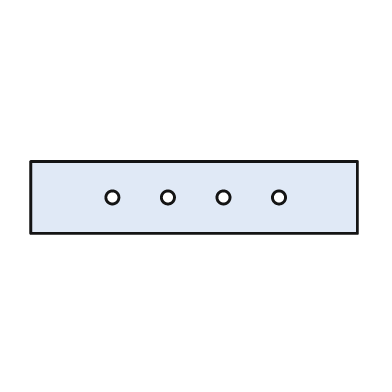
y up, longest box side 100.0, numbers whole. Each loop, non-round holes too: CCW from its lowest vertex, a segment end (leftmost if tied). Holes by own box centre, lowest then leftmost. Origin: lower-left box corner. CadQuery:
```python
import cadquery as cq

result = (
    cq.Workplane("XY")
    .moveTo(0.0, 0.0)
    .lineTo(100.0, 0.0)
    .lineTo(100.0, 22.0)
    .lineTo(0.0, 22.0)
    .close()
    .moveTo(25.0, 11.0)
    .circle(2.0)
    .moveTo(42.0, 11.0)
    .circle(2.0)
    .moveTo(59.0, 11.0)
    .circle(2.0)
    .moveTo(76.0, 11.0)
    .circle(2.0)
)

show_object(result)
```